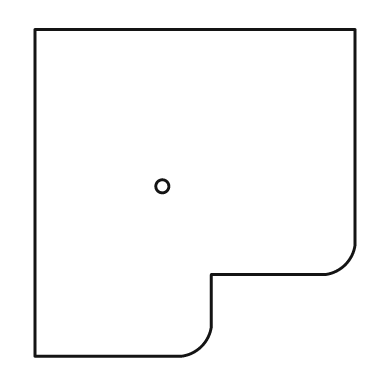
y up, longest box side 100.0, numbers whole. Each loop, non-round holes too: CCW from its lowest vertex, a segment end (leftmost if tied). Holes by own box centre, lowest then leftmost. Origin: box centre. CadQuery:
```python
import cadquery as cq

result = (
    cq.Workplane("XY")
    .moveTo(-49.0, -50.0)
    .lineTo(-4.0, -50.0)
    .threePointArc((2.0, -47.0), (5.0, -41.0))
    .lineTo(5.0, -25.0)
    .lineTo(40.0, -25.0)
    .threePointArc((46.0, -22.0), (49.0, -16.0))
    .lineTo(49.0, 50.0)
    .lineTo(-49.0, 50.0)
    .close()
    .moveTo(-10.0, 2.0)
    .circle(2.0)
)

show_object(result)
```